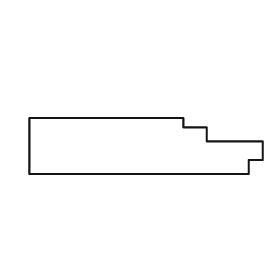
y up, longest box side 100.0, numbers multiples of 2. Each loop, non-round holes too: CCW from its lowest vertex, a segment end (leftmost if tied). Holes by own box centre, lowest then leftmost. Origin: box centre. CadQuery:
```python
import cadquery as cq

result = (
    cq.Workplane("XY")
    .moveTo(-50.0, -12.0)
    .lineTo(44.0, -12.0)
    .lineTo(44.0, -6.0)
    .lineTo(50.0, -6.0)
    .lineTo(50.0, 2.0)
    .lineTo(26.0, 2.0)
    .lineTo(26.0, 8.0)
    .lineTo(16.0, 8.0)
    .lineTo(16.0, 12.0)
    .lineTo(-50.0, 12.0)
    .close()
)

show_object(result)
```